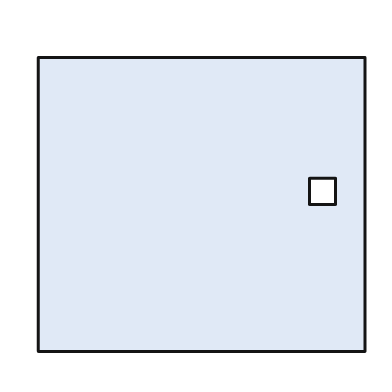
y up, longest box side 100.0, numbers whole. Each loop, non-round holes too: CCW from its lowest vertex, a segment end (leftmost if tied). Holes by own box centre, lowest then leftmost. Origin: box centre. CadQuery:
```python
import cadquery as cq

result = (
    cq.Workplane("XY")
    .moveTo(-50.0, -45.0)
    .lineTo(50.0, -45.0)
    .lineTo(50.0, 45.0)
    .lineTo(-50.0, 45.0)
    .close()
    .moveTo(33.0, 0.0)
    .lineTo(41.0, 0.0)
    .lineTo(41.0, 8.0)
    .lineTo(33.0, 8.0)
    .close()
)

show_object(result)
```